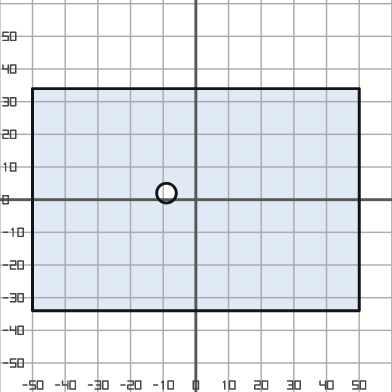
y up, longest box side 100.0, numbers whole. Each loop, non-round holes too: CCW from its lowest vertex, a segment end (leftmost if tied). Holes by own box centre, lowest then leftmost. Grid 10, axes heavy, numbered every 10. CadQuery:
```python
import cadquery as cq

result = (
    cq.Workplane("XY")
    .moveTo(-50.0, -34.0)
    .lineTo(50.0, -34.0)
    .lineTo(50.0, 34.0)
    .lineTo(-50.0, 34.0)
    .close()
    .moveTo(-9.0, 2.0)
    .circle(3.0)
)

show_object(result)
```